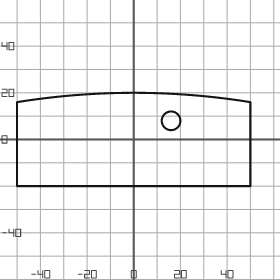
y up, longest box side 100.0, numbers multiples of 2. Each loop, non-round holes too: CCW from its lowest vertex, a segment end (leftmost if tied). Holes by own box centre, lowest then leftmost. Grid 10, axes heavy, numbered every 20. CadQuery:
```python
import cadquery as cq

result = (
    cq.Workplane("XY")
    .moveTo(-50.0, -20.0)
    .lineTo(50.0, -20.0)
    .lineTo(50.0, 16.0)
    .threePointArc((0.0, 20.0), (-50.0, 16.0))
    .close()
    .moveTo(16.0, 8.0)
    .circle(4.0)
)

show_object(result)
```